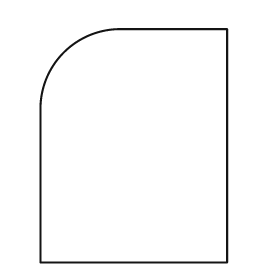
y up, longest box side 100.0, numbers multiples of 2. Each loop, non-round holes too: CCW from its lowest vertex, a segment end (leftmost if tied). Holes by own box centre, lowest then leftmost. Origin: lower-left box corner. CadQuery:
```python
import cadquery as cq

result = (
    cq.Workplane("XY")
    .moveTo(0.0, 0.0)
    .lineTo(80.0, 0.0)
    .lineTo(80.0, 100.0)
    .lineTo(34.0, 100.0)
    .threePointArc((10.0, 90.0), (0.0, 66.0))
    .close()
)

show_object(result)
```